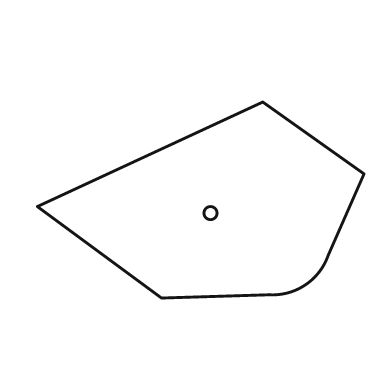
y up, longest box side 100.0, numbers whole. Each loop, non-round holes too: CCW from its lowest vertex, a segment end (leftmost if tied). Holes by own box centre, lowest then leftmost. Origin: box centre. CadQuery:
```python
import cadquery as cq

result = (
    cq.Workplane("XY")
    .moveTo(-12.0, -30.0)
    .lineTo(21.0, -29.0)
    .threePointArc((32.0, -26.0), (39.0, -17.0))
    .lineTo(50.0, 8.0)
    .lineTo(19.0, 30.0)
    .lineTo(-50.0, -2.0)
    .close()
    .moveTo(3.0, -4.0)
    .circle(2.0)
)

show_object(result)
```